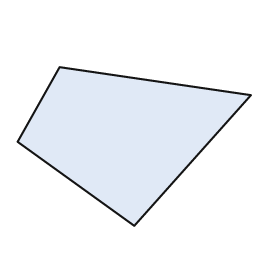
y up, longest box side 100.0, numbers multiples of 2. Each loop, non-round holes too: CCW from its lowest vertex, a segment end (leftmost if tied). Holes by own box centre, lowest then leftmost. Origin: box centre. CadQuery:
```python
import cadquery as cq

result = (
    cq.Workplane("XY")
    .moveTo(0.0, -34.0)
    .lineTo(50.0, 22.0)
    .lineTo(-32.0, 34.0)
    .lineTo(-50.0, 2.0)
    .close()
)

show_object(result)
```